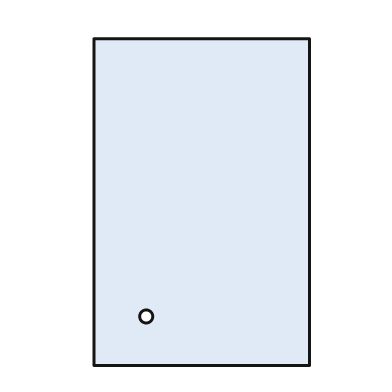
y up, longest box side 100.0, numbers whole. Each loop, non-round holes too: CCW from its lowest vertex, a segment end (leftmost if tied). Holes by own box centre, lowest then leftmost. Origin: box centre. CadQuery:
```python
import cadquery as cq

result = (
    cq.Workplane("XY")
    .moveTo(-33.0, -50.0)
    .lineTo(33.0, -50.0)
    .lineTo(33.0, 50.0)
    .lineTo(-33.0, 50.0)
    .close()
    .moveTo(-17.0, -35.0)
    .circle(2.0)
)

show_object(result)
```